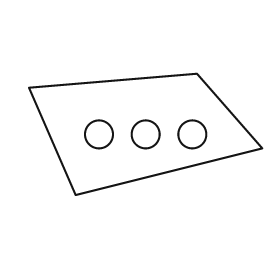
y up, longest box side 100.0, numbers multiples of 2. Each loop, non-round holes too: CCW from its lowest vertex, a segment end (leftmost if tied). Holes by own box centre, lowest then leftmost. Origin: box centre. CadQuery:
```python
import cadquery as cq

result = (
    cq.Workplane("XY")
    .moveTo(-30.0, -26.0)
    .lineTo(50.0, -6.0)
    .lineTo(22.0, 26.0)
    .lineTo(-50.0, 20.0)
    .close()
    .moveTo(-20.0, 0.0)
    .circle(6.0)
    .moveTo(0.0, 0.0)
    .circle(6.0)
    .moveTo(20.0, 0.0)
    .circle(6.0)
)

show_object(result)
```